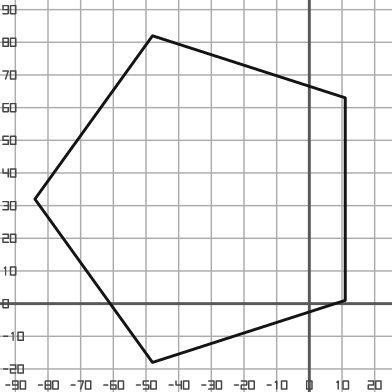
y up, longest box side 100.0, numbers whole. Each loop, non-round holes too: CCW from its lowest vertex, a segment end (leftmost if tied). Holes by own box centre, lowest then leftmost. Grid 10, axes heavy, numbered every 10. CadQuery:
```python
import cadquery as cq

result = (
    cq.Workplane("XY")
    .moveTo(-48.0, -18.0)
    .lineTo(11.0, 1.0)
    .lineTo(11.0, 63.0)
    .lineTo(-48.0, 82.0)
    .lineTo(-84.0, 32.0)
    .close()
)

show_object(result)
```